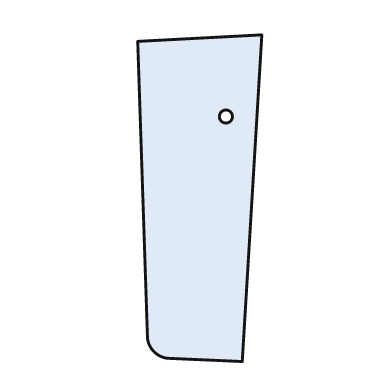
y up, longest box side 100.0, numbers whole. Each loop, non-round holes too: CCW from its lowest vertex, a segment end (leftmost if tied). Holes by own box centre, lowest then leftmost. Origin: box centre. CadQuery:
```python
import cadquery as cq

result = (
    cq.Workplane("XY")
    .moveTo(13.0, -50.0)
    .lineTo(19.0, 50.0)
    .lineTo(-19.0, 48.0)
    .lineTo(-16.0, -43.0)
    .threePointArc((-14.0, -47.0), (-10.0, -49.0))
    .close()
    .moveTo(8.0, 25.0)
    .circle(2.0)
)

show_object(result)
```